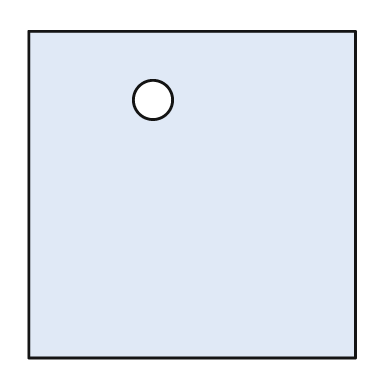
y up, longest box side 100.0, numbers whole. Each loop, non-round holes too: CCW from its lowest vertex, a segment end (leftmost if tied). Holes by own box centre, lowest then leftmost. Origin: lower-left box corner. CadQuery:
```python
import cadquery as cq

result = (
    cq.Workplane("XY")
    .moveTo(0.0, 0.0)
    .lineTo(100.0, 0.0)
    .lineTo(100.0, 100.0)
    .lineTo(0.0, 100.0)
    .close()
    .moveTo(38.0, 79.0)
    .circle(6.0)
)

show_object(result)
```